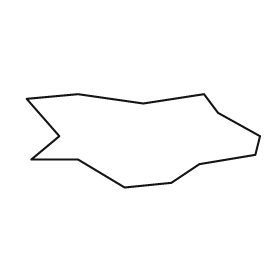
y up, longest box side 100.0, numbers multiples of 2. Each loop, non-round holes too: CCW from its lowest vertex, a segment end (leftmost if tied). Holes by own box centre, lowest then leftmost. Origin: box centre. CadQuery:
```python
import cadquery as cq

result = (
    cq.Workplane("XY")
    .moveTo(-8.0, -20.0)
    .lineTo(12.0, -18.0)
    .lineTo(24.0, -10.0)
    .lineTo(48.0, -6.0)
    .lineTo(50.0, 2.0)
    .lineTo(32.0, 12.0)
    .lineTo(26.0, 20.0)
    .lineTo(0.0, 16.0)
    .lineTo(-28.0, 20.0)
    .lineTo(-50.0, 18.0)
    .lineTo(-36.0, 2.0)
    .lineTo(-48.0, -8.0)
    .lineTo(-28.0, -8.0)
    .close()
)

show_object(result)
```